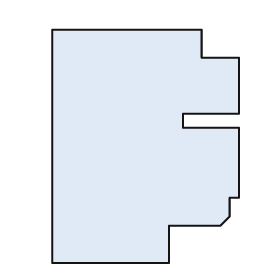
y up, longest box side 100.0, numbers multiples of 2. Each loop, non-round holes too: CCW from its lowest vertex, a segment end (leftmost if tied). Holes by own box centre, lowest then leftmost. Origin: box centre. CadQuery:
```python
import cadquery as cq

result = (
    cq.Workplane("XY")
    .moveTo(-40.0, -50.0)
    .lineTo(10.0, -50.0)
    .lineTo(10.0, -34.0)
    .lineTo(32.0, -34.0)
    .lineTo(36.0, -30.0)
    .lineTo(36.0, -22.0)
    .lineTo(40.0, -22.0)
    .lineTo(40.0, 8.0)
    .lineTo(16.0, 8.0)
    .lineTo(16.0, 14.0)
    .lineTo(40.0, 14.0)
    .lineTo(40.0, 38.0)
    .lineTo(24.0, 38.0)
    .lineTo(24.0, 50.0)
    .lineTo(-40.0, 50.0)
    .close()
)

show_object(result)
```